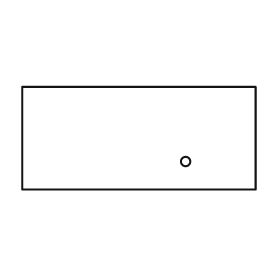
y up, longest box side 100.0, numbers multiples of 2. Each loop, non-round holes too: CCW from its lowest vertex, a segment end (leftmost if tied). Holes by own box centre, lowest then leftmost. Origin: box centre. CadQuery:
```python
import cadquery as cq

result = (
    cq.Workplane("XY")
    .moveTo(-50.0, -22.0)
    .lineTo(50.0, -22.0)
    .lineTo(50.0, 22.0)
    .lineTo(-50.0, 22.0)
    .close()
    .moveTo(20.0, -10.0)
    .circle(2.0)
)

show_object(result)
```